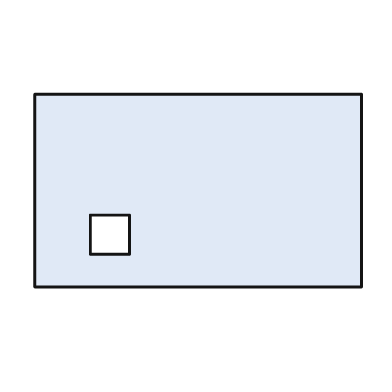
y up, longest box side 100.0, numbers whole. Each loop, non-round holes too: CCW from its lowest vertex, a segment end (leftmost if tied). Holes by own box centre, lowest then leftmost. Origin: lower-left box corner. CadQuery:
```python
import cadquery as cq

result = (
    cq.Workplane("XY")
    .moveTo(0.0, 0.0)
    .lineTo(100.0, 0.0)
    .lineTo(100.0, 59.0)
    .lineTo(0.0, 59.0)
    .close()
    .moveTo(17.0, 10.0)
    .lineTo(29.0, 10.0)
    .lineTo(29.0, 22.0)
    .lineTo(17.0, 22.0)
    .close()
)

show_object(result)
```